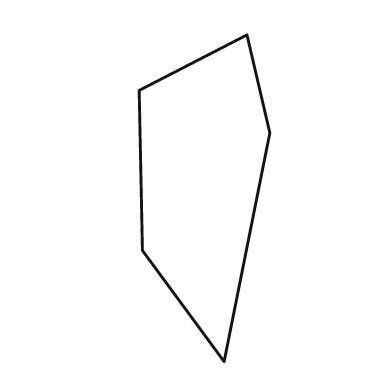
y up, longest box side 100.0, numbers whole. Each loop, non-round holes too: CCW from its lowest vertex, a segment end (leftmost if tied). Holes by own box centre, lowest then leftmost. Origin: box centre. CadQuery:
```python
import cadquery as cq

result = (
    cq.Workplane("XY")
    .moveTo(6.0, -50.0)
    .lineTo(20.0, 20.0)
    .lineTo(13.0, 50.0)
    .lineTo(-20.0, 33.0)
    .lineTo(-19.0, -16.0)
    .close()
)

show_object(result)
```